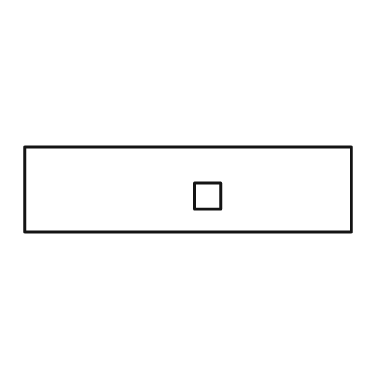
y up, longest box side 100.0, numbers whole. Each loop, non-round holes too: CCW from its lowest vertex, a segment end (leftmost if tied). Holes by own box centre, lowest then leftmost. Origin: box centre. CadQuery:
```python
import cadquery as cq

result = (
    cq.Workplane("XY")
    .moveTo(-50.0, -13.0)
    .lineTo(50.0, -13.0)
    .lineTo(50.0, 13.0)
    .lineTo(-50.0, 13.0)
    .close()
    .moveTo(2.0, -6.0)
    .lineTo(10.0, -6.0)
    .lineTo(10.0, 2.0)
    .lineTo(2.0, 2.0)
    .close()
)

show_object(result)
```